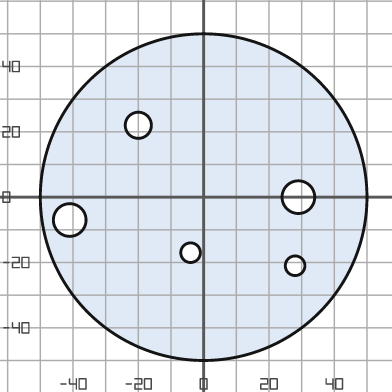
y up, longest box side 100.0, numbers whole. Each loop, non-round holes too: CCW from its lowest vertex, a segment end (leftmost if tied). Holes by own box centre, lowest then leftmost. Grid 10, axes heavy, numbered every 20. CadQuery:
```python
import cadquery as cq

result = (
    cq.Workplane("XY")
    .moveTo(0.0, 0.0)
    .circle(50.0)
    .moveTo(28.0, -21.0)
    .circle(3.0)
    .moveTo(-4.0, -17.0)
    .circle(3.0)
    .moveTo(-41.0, -7.0)
    .circle(5.0)
    .moveTo(29.0, 0.0)
    .circle(5.0)
    .moveTo(-20.0, 22.0)
    .circle(4.0)
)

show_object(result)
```